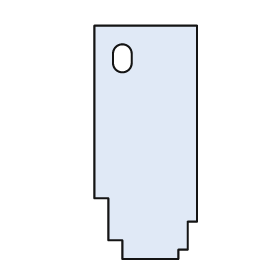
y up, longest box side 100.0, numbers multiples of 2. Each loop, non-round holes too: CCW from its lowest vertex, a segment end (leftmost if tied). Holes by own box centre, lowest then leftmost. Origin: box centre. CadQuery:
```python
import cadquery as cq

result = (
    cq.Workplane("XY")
    .moveTo(-10.0, -50.0)
    .lineTo(14.0, -50.0)
    .lineTo(14.0, -46.0)
    .lineTo(18.0, -46.0)
    .lineTo(18.0, -34.0)
    .lineTo(22.0, -34.0)
    .lineTo(22.0, 50.0)
    .lineTo(-22.0, 50.0)
    .lineTo(-22.0, -24.0)
    .lineTo(-16.0, -24.0)
    .lineTo(-16.0, -42.0)
    .lineTo(-10.0, -42.0)
    .close()
    .moveTo(-14.0, 34.0)
    .threePointArc((-10.0, 30.0), (-6.0, 34.0))
    .lineTo(-6.0, 38.0)
    .threePointArc((-10.0, 42.0), (-14.0, 38.0))
    .close()
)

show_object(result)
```